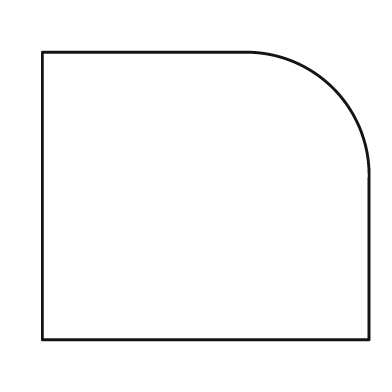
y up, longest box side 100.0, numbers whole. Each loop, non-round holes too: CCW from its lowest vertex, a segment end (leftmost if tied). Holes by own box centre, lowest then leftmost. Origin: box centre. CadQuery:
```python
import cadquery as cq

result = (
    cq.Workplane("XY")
    .moveTo(-50.0, -44.0)
    .lineTo(50.0, -44.0)
    .lineTo(50.0, 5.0)
    .threePointArc((39.0, 33.0), (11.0, 44.0))
    .lineTo(-50.0, 44.0)
    .close()
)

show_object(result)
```